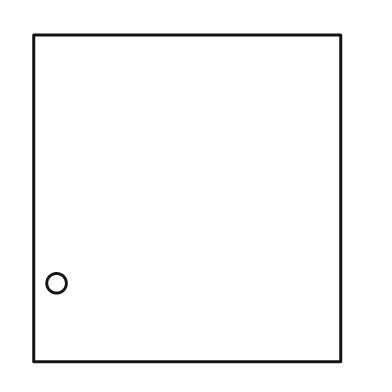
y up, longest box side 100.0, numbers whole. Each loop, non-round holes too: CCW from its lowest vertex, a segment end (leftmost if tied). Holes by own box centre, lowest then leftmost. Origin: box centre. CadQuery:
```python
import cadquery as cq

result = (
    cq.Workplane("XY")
    .moveTo(-47.0, -50.0)
    .lineTo(47.0, -50.0)
    .lineTo(47.0, 50.0)
    .lineTo(-47.0, 50.0)
    .close()
    .moveTo(-40.0, -26.0)
    .circle(3.0)
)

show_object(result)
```